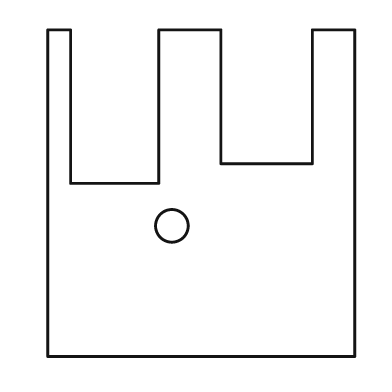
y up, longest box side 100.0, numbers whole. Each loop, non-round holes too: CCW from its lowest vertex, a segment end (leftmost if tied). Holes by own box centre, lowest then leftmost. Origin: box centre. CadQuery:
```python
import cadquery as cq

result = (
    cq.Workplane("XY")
    .moveTo(-47.0, -50.0)
    .lineTo(47.0, -50.0)
    .lineTo(47.0, 50.0)
    .lineTo(34.0, 50.0)
    .lineTo(34.0, 9.0)
    .lineTo(6.0, 9.0)
    .lineTo(6.0, 50.0)
    .lineTo(-13.0, 50.0)
    .lineTo(-13.0, 3.0)
    .lineTo(-40.0, 3.0)
    .lineTo(-40.0, 50.0)
    .lineTo(-47.0, 50.0)
    .close()
    .moveTo(-9.0, -10.0)
    .circle(5.0)
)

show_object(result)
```